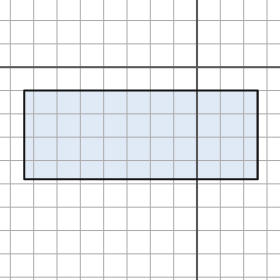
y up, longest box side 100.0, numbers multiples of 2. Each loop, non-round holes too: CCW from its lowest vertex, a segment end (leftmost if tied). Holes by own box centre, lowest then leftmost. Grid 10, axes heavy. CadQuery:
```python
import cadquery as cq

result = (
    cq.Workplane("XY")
    .moveTo(-74.0, -48.0)
    .lineTo(26.0, -48.0)
    .lineTo(26.0, -10.0)
    .lineTo(-74.0, -10.0)
    .close()
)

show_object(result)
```